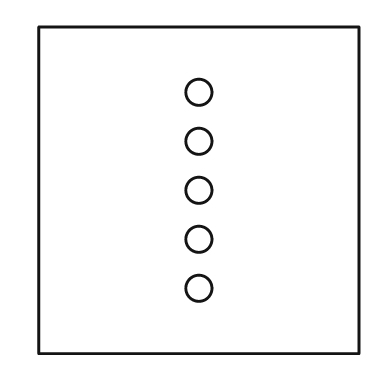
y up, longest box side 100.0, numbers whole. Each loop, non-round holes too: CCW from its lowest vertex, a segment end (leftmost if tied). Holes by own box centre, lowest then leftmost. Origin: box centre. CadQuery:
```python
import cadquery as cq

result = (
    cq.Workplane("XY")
    .moveTo(-49.0, -50.0)
    .lineTo(49.0, -50.0)
    .lineTo(49.0, 50.0)
    .lineTo(-49.0, 50.0)
    .close()
    .moveTo(0.0, -30.0)
    .circle(4.0)
    .moveTo(0.0, -15.0)
    .circle(4.0)
    .moveTo(0.0, 0.0)
    .circle(4.0)
    .moveTo(0.0, 15.0)
    .circle(4.0)
    .moveTo(0.0, 30.0)
    .circle(4.0)
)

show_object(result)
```